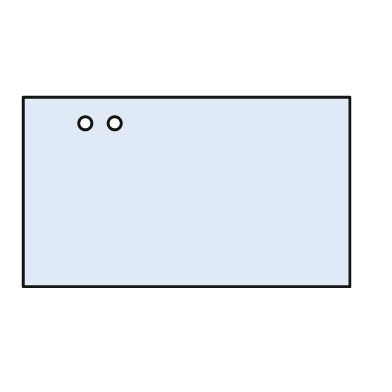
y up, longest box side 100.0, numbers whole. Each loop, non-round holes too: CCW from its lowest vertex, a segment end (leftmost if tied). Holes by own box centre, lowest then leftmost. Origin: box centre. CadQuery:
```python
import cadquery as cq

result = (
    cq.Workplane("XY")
    .moveTo(-50.0, -29.0)
    .lineTo(50.0, -29.0)
    .lineTo(50.0, 29.0)
    .lineTo(-50.0, 29.0)
    .close()
    .moveTo(-31.0, 21.0)
    .circle(2.0)
    .moveTo(-22.0, 21.0)
    .circle(2.0)
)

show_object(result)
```